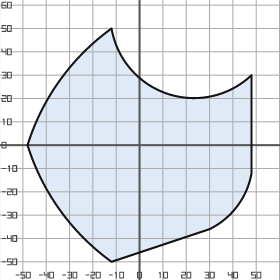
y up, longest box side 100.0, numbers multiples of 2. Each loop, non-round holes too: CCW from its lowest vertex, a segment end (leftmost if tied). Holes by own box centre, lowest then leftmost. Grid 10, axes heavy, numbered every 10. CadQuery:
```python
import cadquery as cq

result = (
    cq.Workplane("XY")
    .moveTo(-12.0, -50.0)
    .lineTo(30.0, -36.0)
    .threePointArc((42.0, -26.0), (48.0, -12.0))
    .lineTo(48.0, 30.0)
    .threePointArc((12.0, 22.0), (-12.0, 50.0))
    .threePointArc((-34.0, 28.0), (-48.0, 0.0))
    .threePointArc((-34.0, -28.0), (-12.0, -50.0))
    .close()
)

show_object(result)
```